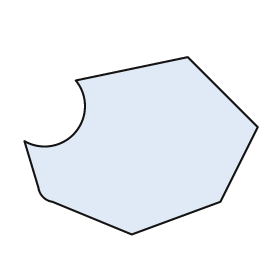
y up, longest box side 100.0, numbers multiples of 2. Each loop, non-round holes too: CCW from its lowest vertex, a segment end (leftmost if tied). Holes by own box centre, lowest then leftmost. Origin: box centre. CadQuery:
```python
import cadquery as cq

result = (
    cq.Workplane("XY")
    .moveTo(-4.0, -38.0)
    .lineTo(34.0, -24.0)
    .lineTo(50.0, 8.0)
    .lineTo(20.0, 38.0)
    .lineTo(-28.0, 28.0)
    .threePointArc((-28.0, 6.0), (-50.0, 2.0))
    .lineTo(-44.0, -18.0)
    .threePointArc((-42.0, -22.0), (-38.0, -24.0))
    .close()
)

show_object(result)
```